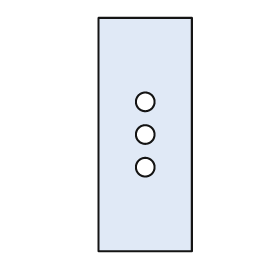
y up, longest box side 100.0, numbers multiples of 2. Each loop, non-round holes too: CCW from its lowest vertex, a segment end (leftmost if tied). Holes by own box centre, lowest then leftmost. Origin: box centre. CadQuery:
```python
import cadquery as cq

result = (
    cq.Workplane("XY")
    .moveTo(-20.0, -50.0)
    .lineTo(20.0, -50.0)
    .lineTo(20.0, 50.0)
    .lineTo(-20.0, 50.0)
    .close()
    .moveTo(0.0, -14.0)
    .circle(4.0)
    .moveTo(0.0, 0.0)
    .circle(4.0)
    .moveTo(0.0, 14.0)
    .circle(4.0)
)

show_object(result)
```